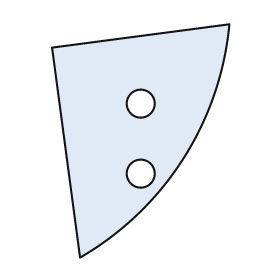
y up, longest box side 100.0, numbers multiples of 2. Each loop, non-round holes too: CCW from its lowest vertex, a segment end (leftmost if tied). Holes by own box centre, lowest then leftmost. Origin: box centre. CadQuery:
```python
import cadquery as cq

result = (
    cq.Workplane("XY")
    .moveTo(-26.0, -50.0)
    .threePointArc((18.0, -8.0), (38.0, 50.0))
    .lineTo(-38.0, 40.0)
    .close()
    .moveTo(0.0, -14.0)
    .circle(6.0)
    .moveTo(0.0, 16.0)
    .circle(6.0)
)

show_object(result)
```